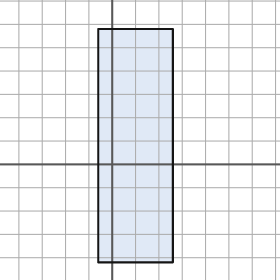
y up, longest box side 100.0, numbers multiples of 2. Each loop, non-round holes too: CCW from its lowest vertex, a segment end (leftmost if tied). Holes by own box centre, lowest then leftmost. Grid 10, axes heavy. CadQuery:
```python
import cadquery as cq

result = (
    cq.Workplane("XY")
    .moveTo(-6.0, -42.0)
    .lineTo(26.0, -42.0)
    .lineTo(26.0, 58.0)
    .lineTo(-6.0, 58.0)
    .close()
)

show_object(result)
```